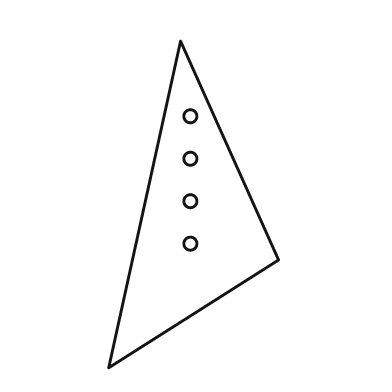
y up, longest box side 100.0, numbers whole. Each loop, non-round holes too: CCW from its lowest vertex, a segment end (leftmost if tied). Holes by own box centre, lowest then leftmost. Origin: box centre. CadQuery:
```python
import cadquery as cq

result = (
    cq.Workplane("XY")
    .moveTo(-26.0, -50.0)
    .lineTo(26.0, -17.0)
    .lineTo(-4.0, 50.0)
    .close()
    .moveTo(-1.0, -12.0)
    .circle(2.0)
    .moveTo(-1.0, 1.0)
    .circle(2.0)
    .moveTo(-1.0, 14.0)
    .circle(2.0)
    .moveTo(-1.0, 27.0)
    .circle(2.0)
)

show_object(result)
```